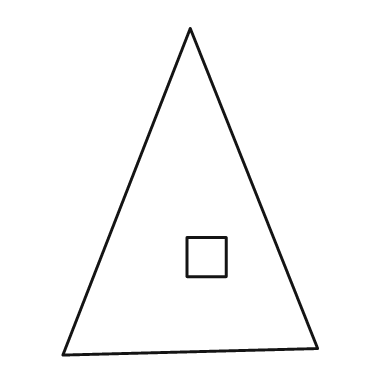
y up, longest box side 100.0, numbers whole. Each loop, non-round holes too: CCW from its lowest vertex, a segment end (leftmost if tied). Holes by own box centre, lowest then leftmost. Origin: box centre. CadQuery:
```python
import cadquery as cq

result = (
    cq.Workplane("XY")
    .moveTo(-39.0, -50.0)
    .lineTo(39.0, -48.0)
    .lineTo(0.0, 50.0)
    .close()
    .moveTo(-1.0, -26.0)
    .lineTo(11.0, -26.0)
    .lineTo(11.0, -14.0)
    .lineTo(-1.0, -14.0)
    .close()
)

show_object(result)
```